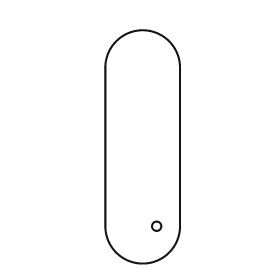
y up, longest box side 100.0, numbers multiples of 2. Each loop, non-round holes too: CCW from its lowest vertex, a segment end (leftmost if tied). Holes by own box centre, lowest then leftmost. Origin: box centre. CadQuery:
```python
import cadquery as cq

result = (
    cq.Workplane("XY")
    .moveTo(-16.0, -34.0)
    .threePointArc((0.0, -50.0), (16.0, -34.0))
    .lineTo(16.0, 34.0)
    .threePointArc((0.0, 50.0), (-16.0, 34.0))
    .close()
    .moveTo(6.0, -34.0)
    .circle(2.0)
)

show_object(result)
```